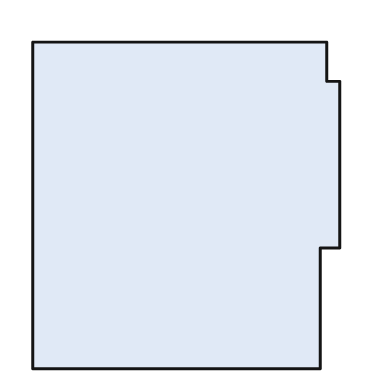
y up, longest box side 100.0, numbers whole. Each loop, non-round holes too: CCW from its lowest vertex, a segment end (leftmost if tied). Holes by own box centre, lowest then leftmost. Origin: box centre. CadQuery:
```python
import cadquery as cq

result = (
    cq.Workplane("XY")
    .moveTo(-47.0, -50.0)
    .lineTo(41.0, -50.0)
    .lineTo(41.0, -13.0)
    .lineTo(47.0, -13.0)
    .lineTo(47.0, 38.0)
    .lineTo(43.0, 38.0)
    .lineTo(43.0, 50.0)
    .lineTo(-47.0, 50.0)
    .close()
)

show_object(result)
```